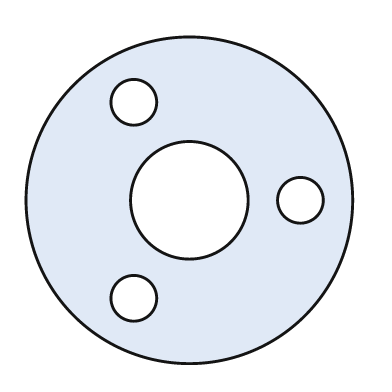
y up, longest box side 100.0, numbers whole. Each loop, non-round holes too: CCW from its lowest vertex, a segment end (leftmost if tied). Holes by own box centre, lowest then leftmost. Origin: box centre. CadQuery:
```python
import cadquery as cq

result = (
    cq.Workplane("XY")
    .moveTo(0.0, 0.0)
    .circle(50.0)
    .moveTo(-17.0, -30.0)
    .circle(7.0)
    .moveTo(0.0, 0.0)
    .circle(18.0)
    .moveTo(34.0, 0.0)
    .circle(7.0)
    .moveTo(-17.0, 30.0)
    .circle(7.0)
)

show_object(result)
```